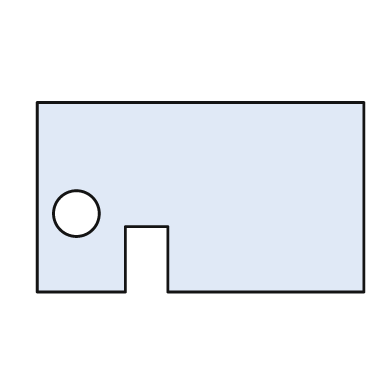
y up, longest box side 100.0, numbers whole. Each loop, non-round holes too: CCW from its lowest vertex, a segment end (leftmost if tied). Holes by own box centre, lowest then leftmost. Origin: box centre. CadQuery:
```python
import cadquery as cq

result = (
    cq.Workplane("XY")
    .moveTo(-50.0, -29.0)
    .lineTo(-23.0, -29.0)
    .lineTo(-23.0, -9.0)
    .lineTo(-10.0, -9.0)
    .lineTo(-10.0, -29.0)
    .lineTo(50.0, -29.0)
    .lineTo(50.0, 29.0)
    .lineTo(-50.0, 29.0)
    .close()
    .moveTo(-38.0, -5.0)
    .circle(7.0)
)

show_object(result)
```